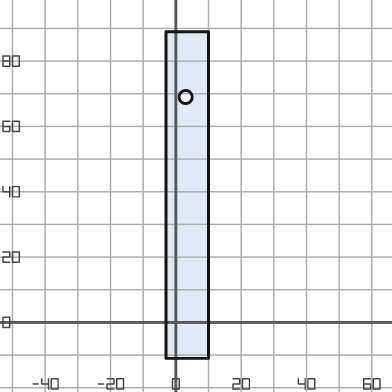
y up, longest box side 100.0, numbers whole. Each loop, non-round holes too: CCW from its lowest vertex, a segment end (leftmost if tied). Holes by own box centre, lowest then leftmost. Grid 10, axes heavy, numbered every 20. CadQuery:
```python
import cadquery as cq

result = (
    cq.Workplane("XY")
    .moveTo(-3.0, -11.0)
    .lineTo(10.0, -11.0)
    .lineTo(10.0, 89.0)
    .lineTo(-3.0, 89.0)
    .close()
    .moveTo(3.0, 69.0)
    .circle(2.0)
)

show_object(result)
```